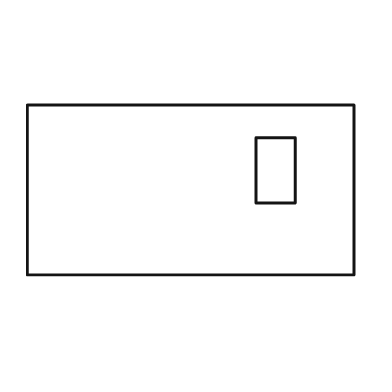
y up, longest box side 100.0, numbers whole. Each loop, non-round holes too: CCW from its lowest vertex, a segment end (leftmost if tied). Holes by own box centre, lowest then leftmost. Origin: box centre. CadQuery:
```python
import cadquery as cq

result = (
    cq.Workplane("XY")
    .moveTo(-50.0, -26.0)
    .lineTo(50.0, -26.0)
    .lineTo(50.0, 26.0)
    .lineTo(-50.0, 26.0)
    .close()
    .moveTo(20.0, -4.0)
    .lineTo(32.0, -4.0)
    .lineTo(32.0, 16.0)
    .lineTo(20.0, 16.0)
    .close()
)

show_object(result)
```